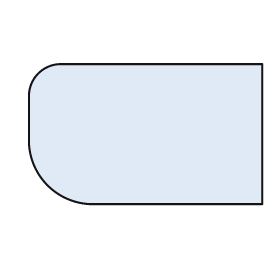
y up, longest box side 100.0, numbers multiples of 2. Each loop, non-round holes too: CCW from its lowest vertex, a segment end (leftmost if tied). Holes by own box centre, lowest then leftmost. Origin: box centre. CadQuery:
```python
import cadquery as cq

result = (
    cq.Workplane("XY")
    .moveTo(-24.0, -30.0)
    .lineTo(50.0, -30.0)
    .lineTo(50.0, 30.0)
    .lineTo(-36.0, 30.0)
    .threePointArc((-46.0, 26.0), (-50.0, 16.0))
    .lineTo(-50.0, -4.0)
    .threePointArc((-42.0, -22.0), (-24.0, -30.0))
    .close()
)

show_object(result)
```